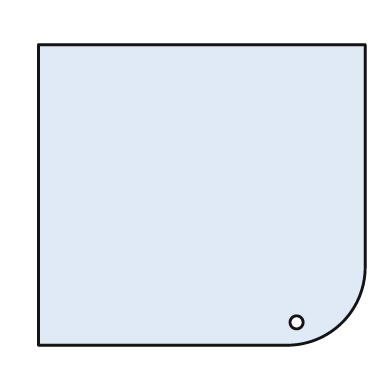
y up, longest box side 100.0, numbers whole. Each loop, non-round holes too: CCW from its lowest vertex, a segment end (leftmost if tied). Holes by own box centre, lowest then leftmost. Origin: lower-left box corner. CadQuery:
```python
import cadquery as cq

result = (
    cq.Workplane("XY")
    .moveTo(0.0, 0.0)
    .lineTo(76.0, 0.0)
    .threePointArc((93.0, 7.0), (100.0, 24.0))
    .lineTo(100.0, 92.0)
    .lineTo(0.0, 92.0)
    .close()
    .moveTo(79.0, 7.0)
    .circle(2.0)
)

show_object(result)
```